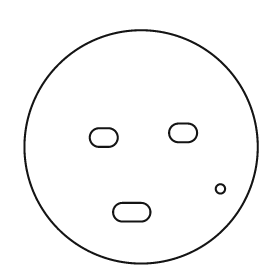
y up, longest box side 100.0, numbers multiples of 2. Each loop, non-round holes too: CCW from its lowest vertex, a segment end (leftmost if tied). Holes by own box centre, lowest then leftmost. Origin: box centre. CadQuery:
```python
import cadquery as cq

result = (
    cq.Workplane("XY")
    .moveTo(0.0, 0.0)
    .circle(50.0)
    .moveTo(-8.0, -32.0)
    .lineTo(0.0, -32.0)
    .threePointArc((4.0, -28.0), (0.0, -24.0))
    .lineTo(-8.0, -24.0)
    .threePointArc((-12.0, -28.0), (-8.0, -32.0))
    .close()
    .moveTo(34.0, -18.0)
    .circle(2.0)
    .moveTo(-18.0, 0.0)
    .lineTo(-14.0, 0.0)
    .threePointArc((-10.0, 4.0), (-14.0, 8.0))
    .lineTo(-18.0, 8.0)
    .threePointArc((-22.0, 4.0), (-18.0, 0.0))
    .close()
    .moveTo(16.0, 2.0)
    .lineTo(20.0, 2.0)
    .threePointArc((24.0, 6.0), (20.0, 10.0))
    .lineTo(16.0, 10.0)
    .threePointArc((12.0, 6.0), (16.0, 2.0))
    .close()
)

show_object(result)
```